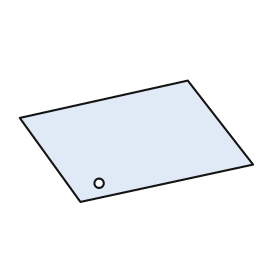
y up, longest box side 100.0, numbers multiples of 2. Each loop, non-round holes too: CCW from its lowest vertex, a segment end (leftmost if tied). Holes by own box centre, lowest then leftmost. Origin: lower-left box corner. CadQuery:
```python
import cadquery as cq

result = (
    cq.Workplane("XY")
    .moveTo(26.0, 0.0)
    .lineTo(100.0, 16.0)
    .lineTo(72.0, 52.0)
    .lineTo(0.0, 36.0)
    .close()
    .moveTo(34.0, 8.0)
    .circle(2.0)
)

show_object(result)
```